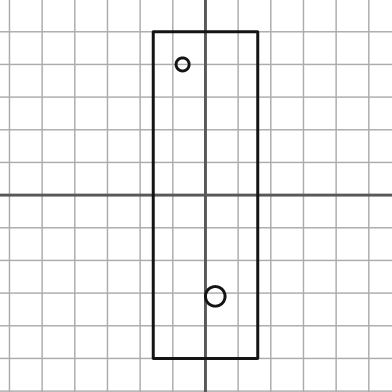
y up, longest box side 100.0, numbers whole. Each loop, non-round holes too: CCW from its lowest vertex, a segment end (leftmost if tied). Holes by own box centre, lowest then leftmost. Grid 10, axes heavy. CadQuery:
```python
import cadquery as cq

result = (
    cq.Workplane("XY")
    .moveTo(-16.0, -50.0)
    .lineTo(16.0, -50.0)
    .lineTo(16.0, 50.0)
    .lineTo(-16.0, 50.0)
    .close()
    .moveTo(3.0, -31.0)
    .circle(3.0)
    .moveTo(-7.0, 40.0)
    .circle(2.0)
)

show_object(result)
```